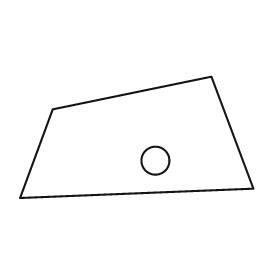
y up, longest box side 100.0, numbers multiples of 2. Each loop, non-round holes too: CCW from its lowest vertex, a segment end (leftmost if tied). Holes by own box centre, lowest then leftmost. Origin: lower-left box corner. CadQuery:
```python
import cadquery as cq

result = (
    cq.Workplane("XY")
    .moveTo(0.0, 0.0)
    .lineTo(100.0, 4.0)
    .lineTo(82.0, 52.0)
    .lineTo(14.0, 38.0)
    .close()
    .moveTo(58.0, 16.0)
    .circle(6.0)
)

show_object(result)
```